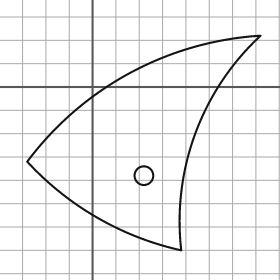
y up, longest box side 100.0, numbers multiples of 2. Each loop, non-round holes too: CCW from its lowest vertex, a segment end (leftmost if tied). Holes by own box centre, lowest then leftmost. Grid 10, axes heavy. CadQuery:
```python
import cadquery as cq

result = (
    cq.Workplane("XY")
    .moveTo(38.0, -70.0)
    .threePointArc((44.0, -20.0), (72.0, 22.0))
    .threePointArc((16.0, 6.0), (-28.0, -32.0))
    .threePointArc((2.0, -56.0), (38.0, -70.0))
    .close()
    .moveTo(22.0, -38.0)
    .circle(4.0)
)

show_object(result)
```